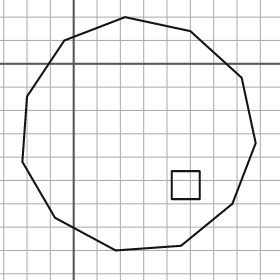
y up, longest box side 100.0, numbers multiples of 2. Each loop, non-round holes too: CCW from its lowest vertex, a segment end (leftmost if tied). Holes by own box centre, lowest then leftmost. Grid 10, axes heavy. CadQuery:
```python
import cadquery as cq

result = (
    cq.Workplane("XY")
    .moveTo(18.0, -80.0)
    .lineTo(46.0, -78.0)
    .lineTo(68.0, -60.0)
    .lineTo(78.0, -34.0)
    .lineTo(72.0, -6.0)
    .lineTo(50.0, 14.0)
    .lineTo(22.0, 20.0)
    .lineTo(-4.0, 10.0)
    .lineTo(-20.0, -14.0)
    .lineTo(-22.0, -42.0)
    .lineTo(-8.0, -66.0)
    .close()
    .moveTo(42.0, -58.0)
    .lineTo(54.0, -58.0)
    .lineTo(54.0, -46.0)
    .lineTo(42.0, -46.0)
    .close()
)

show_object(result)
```